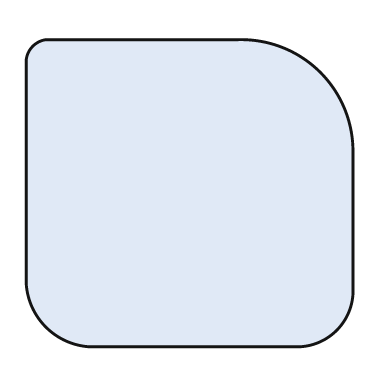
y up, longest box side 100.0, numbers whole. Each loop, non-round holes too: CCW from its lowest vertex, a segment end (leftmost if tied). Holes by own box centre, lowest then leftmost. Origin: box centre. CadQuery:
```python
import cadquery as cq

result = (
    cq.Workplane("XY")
    .moveTo(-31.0, -47.0)
    .lineTo(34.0, -47.0)
    .threePointArc((45.0, -42.0), (50.0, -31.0))
    .lineTo(50.0, 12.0)
    .threePointArc((40.0, 37.0), (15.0, 47.0))
    .lineTo(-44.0, 47.0)
    .threePointArc((-48.0, 45.0), (-50.0, 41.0))
    .lineTo(-50.0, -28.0)
    .threePointArc((-44.0, -41.0), (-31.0, -47.0))
    .close()
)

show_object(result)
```